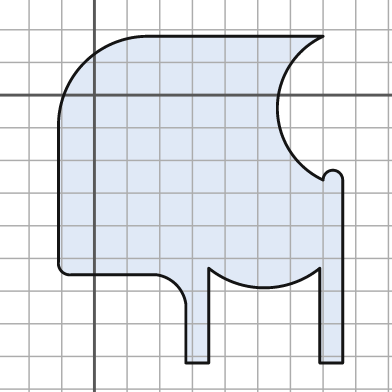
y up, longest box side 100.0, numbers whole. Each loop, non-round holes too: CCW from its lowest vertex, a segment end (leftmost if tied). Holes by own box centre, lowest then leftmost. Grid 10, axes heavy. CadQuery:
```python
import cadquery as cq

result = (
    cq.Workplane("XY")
    .moveTo(28.0, -82.0)
    .lineTo(35.0, -82.0)
    .lineTo(35.0, -53.0)
    .threePointArc((52.0, -59.0), (69.0, -53.0))
    .lineTo(69.0, -82.0)
    .lineTo(76.0, -82.0)
    .lineTo(76.0, -26.0)
    .threePointArc((73.0, -23.0), (70.0, -26.0))
    .threePointArc((56.0, -4.0), (70.0, 18.0))
    .lineTo(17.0, 18.0)
    .threePointArc((-3.0, 10.0), (-11.0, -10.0))
    .lineTo(-11.0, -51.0)
    .threePointArc((-10.0, -54.0), (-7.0, -55.0))
    .lineTo(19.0, -55.0)
    .threePointArc((25.0, -58.0), (28.0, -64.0))
    .close()
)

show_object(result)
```